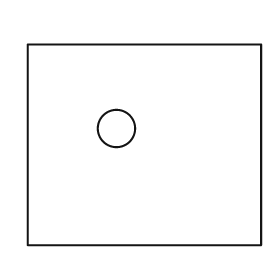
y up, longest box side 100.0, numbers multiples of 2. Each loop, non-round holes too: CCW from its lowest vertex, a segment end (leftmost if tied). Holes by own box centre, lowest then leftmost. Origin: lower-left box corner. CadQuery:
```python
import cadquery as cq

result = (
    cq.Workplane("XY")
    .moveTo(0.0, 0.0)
    .lineTo(100.0, 0.0)
    .lineTo(100.0, 86.0)
    .lineTo(0.0, 86.0)
    .close()
    .moveTo(38.0, 50.0)
    .circle(8.0)
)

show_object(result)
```